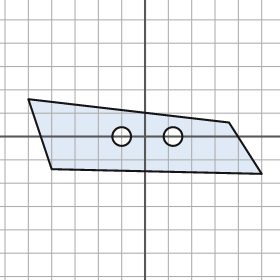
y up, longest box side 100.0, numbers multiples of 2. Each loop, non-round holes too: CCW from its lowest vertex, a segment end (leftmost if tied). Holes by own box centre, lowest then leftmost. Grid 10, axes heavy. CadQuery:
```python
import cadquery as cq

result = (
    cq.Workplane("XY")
    .moveTo(50.0, -16.0)
    .lineTo(36.0, 6.0)
    .lineTo(-50.0, 16.0)
    .lineTo(-40.0, -14.0)
    .close()
    .moveTo(-10.0, 0.0)
    .circle(4.0)
    .moveTo(12.0, 0.0)
    .circle(4.0)
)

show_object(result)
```